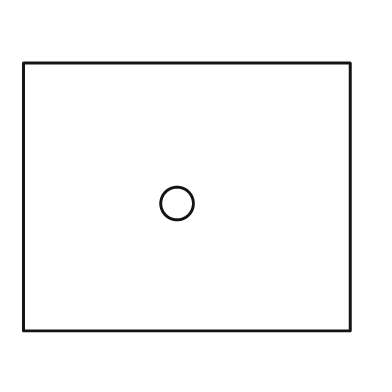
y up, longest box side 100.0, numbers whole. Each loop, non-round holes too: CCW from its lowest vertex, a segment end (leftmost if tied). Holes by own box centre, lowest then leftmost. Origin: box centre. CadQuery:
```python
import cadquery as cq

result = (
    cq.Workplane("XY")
    .moveTo(-50.0, -41.0)
    .lineTo(50.0, -41.0)
    .lineTo(50.0, 41.0)
    .lineTo(-50.0, 41.0)
    .close()
    .moveTo(-3.0, -2.0)
    .circle(5.0)
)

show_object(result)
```